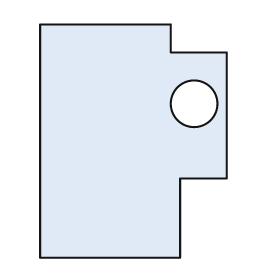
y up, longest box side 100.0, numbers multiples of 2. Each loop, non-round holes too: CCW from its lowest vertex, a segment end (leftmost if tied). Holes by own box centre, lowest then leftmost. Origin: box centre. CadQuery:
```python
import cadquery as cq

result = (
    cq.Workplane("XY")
    .moveTo(-40.0, -50.0)
    .lineTo(20.0, -50.0)
    .lineTo(20.0, -16.0)
    .lineTo(40.0, -16.0)
    .lineTo(40.0, 38.0)
    .lineTo(16.0, 38.0)
    .lineTo(16.0, 50.0)
    .lineTo(-40.0, 50.0)
    .close()
    .moveTo(26.0, 16.0)
    .circle(10.0)
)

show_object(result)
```